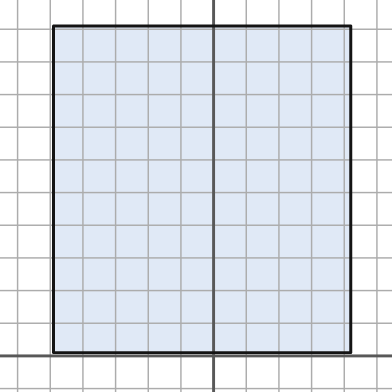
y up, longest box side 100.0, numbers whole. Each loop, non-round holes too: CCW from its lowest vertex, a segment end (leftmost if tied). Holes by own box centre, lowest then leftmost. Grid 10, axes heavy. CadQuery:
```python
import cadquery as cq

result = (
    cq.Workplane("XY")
    .moveTo(-49.0, 1.0)
    .lineTo(42.0, 1.0)
    .lineTo(42.0, 101.0)
    .lineTo(-49.0, 101.0)
    .close()
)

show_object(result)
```